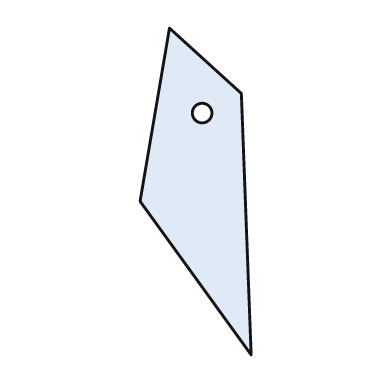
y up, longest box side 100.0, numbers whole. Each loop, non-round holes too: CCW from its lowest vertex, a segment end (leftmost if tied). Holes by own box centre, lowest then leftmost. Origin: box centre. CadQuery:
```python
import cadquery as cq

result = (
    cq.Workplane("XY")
    .moveTo(17.0, -50.0)
    .lineTo(14.0, 30.0)
    .lineTo(-8.0, 50.0)
    .lineTo(-17.0, -3.0)
    .close()
    .moveTo(2.0, 24.0)
    .circle(3.0)
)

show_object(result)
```